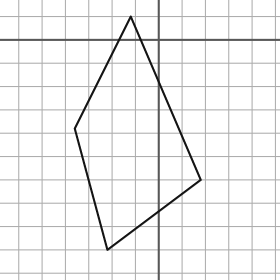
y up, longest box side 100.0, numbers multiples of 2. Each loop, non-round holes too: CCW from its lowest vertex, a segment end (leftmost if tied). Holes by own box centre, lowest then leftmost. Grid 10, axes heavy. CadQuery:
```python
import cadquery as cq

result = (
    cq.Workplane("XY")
    .moveTo(-22.0, -90.0)
    .lineTo(18.0, -60.0)
    .lineTo(-12.0, 10.0)
    .lineTo(-36.0, -38.0)
    .close()
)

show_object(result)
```